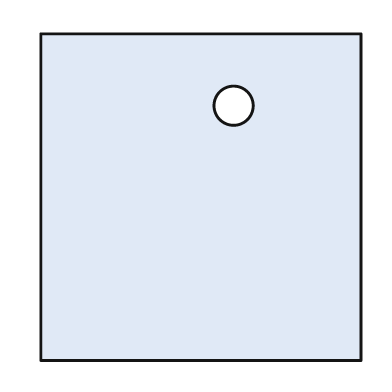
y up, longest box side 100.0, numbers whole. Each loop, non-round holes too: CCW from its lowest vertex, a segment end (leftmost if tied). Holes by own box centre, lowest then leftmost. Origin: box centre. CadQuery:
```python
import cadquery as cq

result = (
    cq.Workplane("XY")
    .moveTo(-49.0, -50.0)
    .lineTo(49.0, -50.0)
    .lineTo(49.0, 50.0)
    .lineTo(-49.0, 50.0)
    .close()
    .moveTo(10.0, 28.0)
    .circle(6.0)
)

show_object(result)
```